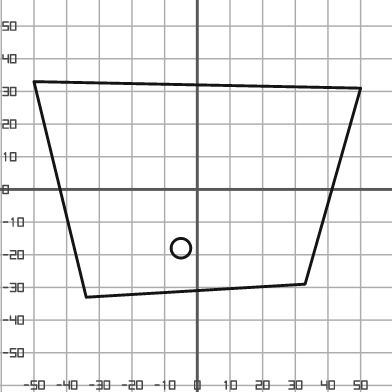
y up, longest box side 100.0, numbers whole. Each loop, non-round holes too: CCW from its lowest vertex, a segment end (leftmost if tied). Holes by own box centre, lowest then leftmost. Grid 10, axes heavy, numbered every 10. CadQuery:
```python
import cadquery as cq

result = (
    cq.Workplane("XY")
    .moveTo(-34.0, -33.0)
    .lineTo(33.0, -29.0)
    .lineTo(50.0, 31.0)
    .lineTo(-50.0, 33.0)
    .close()
    .moveTo(-5.0, -18.0)
    .circle(3.0)
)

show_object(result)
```